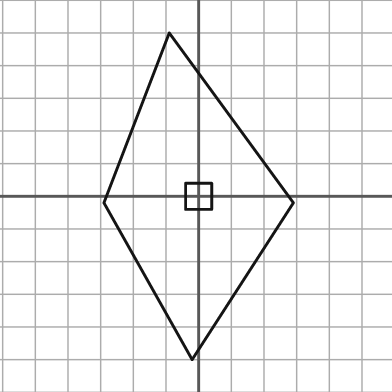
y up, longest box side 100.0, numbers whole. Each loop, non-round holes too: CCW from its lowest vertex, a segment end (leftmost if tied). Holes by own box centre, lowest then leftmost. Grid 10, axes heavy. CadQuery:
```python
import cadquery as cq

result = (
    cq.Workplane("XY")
    .moveTo(-2.0, -50.0)
    .lineTo(29.0, -2.0)
    .lineTo(-9.0, 50.0)
    .lineTo(-29.0, -2.0)
    .close()
    .moveTo(-4.0, -4.0)
    .lineTo(4.0, -4.0)
    .lineTo(4.0, 4.0)
    .lineTo(-4.0, 4.0)
    .close()
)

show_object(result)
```